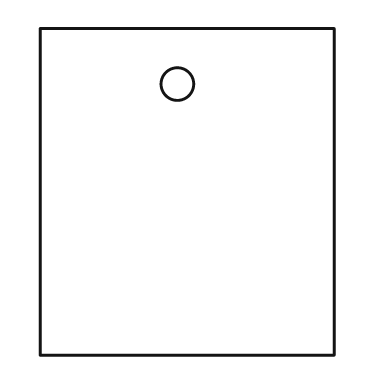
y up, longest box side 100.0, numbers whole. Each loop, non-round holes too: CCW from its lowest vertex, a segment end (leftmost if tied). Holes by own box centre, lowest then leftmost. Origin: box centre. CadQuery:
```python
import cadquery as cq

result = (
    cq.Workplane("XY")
    .moveTo(-45.0, -50.0)
    .lineTo(45.0, -50.0)
    .lineTo(45.0, 50.0)
    .lineTo(-45.0, 50.0)
    .close()
    .moveTo(-3.0, 33.0)
    .circle(5.0)
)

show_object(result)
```